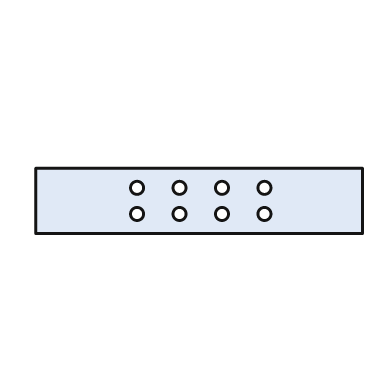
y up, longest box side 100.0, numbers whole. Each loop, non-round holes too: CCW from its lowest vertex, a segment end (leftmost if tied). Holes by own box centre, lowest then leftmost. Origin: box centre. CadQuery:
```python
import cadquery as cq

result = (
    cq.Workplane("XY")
    .moveTo(-50.0, -10.0)
    .lineTo(50.0, -10.0)
    .lineTo(50.0, 10.0)
    .lineTo(-50.0, 10.0)
    .close()
    .moveTo(-19.0, -4.0)
    .circle(2.0)
    .moveTo(-6.0, -4.0)
    .circle(2.0)
    .moveTo(7.0, -4.0)
    .circle(2.0)
    .moveTo(20.0, -4.0)
    .circle(2.0)
    .moveTo(-19.0, 4.0)
    .circle(2.0)
    .moveTo(-6.0, 4.0)
    .circle(2.0)
    .moveTo(7.0, 4.0)
    .circle(2.0)
    .moveTo(20.0, 4.0)
    .circle(2.0)
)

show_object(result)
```